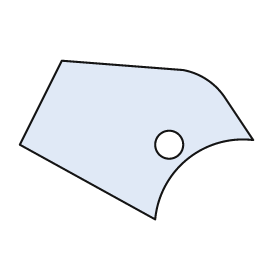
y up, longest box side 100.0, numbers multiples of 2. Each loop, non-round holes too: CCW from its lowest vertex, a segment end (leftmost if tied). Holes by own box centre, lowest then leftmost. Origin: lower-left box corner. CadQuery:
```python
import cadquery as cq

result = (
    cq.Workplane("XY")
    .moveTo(58.0, 0.0)
    .threePointArc((72.0, 26.0), (100.0, 34.0))
    .lineTo(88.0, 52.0)
    .threePointArc((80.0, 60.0), (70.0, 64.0))
    .lineTo(18.0, 68.0)
    .lineTo(0.0, 32.0)
    .close()
    .moveTo(64.0, 32.0)
    .circle(6.0)
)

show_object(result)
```